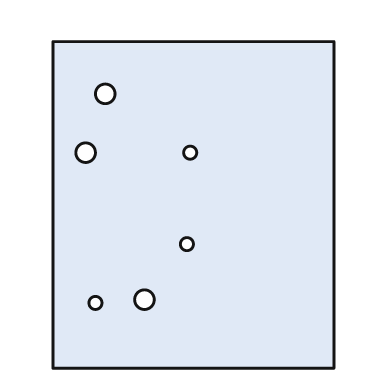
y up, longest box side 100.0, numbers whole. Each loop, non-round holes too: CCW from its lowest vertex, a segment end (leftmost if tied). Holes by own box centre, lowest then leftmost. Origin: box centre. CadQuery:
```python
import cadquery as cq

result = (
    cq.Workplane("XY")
    .moveTo(-43.0, -50.0)
    .lineTo(43.0, -50.0)
    .lineTo(43.0, 50.0)
    .lineTo(-43.0, 50.0)
    .close()
    .moveTo(-30.0, -30.0)
    .circle(2.0)
    .moveTo(-15.0, -29.0)
    .circle(3.0)
    .moveTo(-2.0, -12.0)
    .circle(2.0)
    .moveTo(-33.0, 16.0)
    .circle(3.0)
    .moveTo(-1.0, 16.0)
    .circle(2.0)
    .moveTo(-27.0, 34.0)
    .circle(3.0)
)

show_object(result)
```